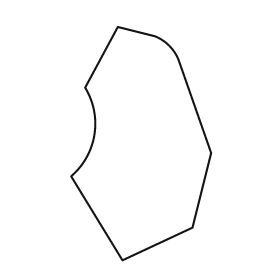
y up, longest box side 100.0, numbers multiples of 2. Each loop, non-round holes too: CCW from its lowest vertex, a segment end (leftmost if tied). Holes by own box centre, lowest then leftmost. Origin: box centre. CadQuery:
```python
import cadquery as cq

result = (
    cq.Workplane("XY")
    .moveTo(-8.0, -50.0)
    .lineTo(22.0, -36.0)
    .lineTo(30.0, -4.0)
    .lineTo(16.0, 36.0)
    .threePointArc((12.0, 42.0), (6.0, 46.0))
    .lineTo(-10.0, 50.0)
    .lineTo(-24.0, 24.0)
    .threePointArc((-20.0, 4.0), (-30.0, -14.0))
    .close()
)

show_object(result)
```